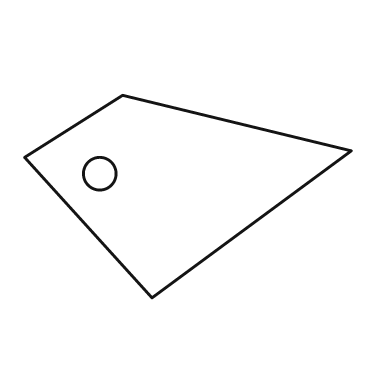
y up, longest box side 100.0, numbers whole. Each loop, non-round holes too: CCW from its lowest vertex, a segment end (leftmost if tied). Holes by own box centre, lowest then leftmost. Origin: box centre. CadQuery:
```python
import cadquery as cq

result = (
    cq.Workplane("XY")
    .moveTo(-11.0, -31.0)
    .lineTo(50.0, 14.0)
    .lineTo(-20.0, 31.0)
    .lineTo(-50.0, 12.0)
    .close()
    .moveTo(-27.0, 7.0)
    .circle(5.0)
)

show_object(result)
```